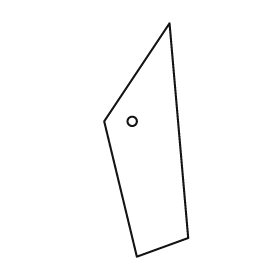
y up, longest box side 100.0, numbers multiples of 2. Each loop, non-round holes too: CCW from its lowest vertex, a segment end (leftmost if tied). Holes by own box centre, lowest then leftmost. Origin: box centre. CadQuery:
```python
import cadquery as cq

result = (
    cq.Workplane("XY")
    .moveTo(-4.0, -50.0)
    .lineTo(18.0, -42.0)
    .lineTo(10.0, 50.0)
    .lineTo(-18.0, 8.0)
    .close()
    .moveTo(-6.0, 8.0)
    .circle(2.0)
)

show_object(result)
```